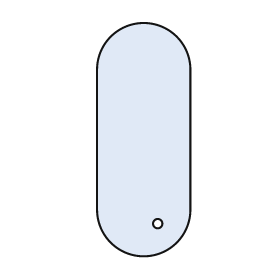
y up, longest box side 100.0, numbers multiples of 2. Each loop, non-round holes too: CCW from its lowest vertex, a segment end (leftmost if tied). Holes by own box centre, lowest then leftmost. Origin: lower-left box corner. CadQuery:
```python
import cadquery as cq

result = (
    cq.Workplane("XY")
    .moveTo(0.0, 20.0)
    .threePointArc((20.0, 0.0), (40.0, 20.0))
    .lineTo(40.0, 80.0)
    .threePointArc((20.0, 100.0), (0.0, 80.0))
    .close()
    .moveTo(26.0, 14.0)
    .circle(2.0)
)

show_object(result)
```